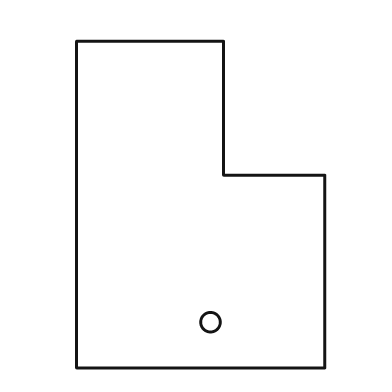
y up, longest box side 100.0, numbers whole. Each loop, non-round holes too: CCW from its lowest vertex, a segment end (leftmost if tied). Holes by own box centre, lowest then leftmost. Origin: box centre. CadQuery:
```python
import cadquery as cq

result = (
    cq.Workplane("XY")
    .moveTo(-38.0, -50.0)
    .lineTo(38.0, -50.0)
    .lineTo(38.0, 9.0)
    .lineTo(7.0, 9.0)
    .lineTo(7.0, 50.0)
    .lineTo(-38.0, 50.0)
    .close()
    .moveTo(3.0, -36.0)
    .circle(3.0)
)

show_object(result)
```